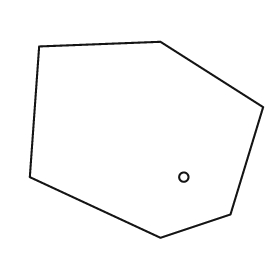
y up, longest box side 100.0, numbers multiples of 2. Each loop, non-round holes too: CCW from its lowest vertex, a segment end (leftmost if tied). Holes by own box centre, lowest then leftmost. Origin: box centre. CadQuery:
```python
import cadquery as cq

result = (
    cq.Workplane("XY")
    .moveTo(6.0, -42.0)
    .lineTo(36.0, -32.0)
    .lineTo(50.0, 14.0)
    .lineTo(6.0, 42.0)
    .lineTo(-46.0, 40.0)
    .lineTo(-50.0, -16.0)
    .close()
    .moveTo(16.0, -16.0)
    .circle(2.0)
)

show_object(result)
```